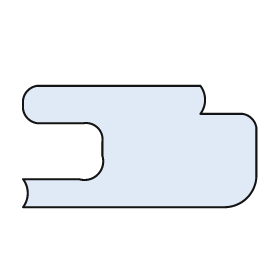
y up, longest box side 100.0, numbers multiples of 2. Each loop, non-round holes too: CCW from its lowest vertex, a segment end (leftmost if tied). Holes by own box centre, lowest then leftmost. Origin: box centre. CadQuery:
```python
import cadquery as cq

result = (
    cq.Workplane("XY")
    .moveTo(-50.0, -26.0)
    .lineTo(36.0, -26.0)
    .threePointArc((46.0, -22.0), (50.0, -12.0))
    .lineTo(50.0, 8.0)
    .threePointArc((48.0, 12.0), (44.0, 14.0))
    .lineTo(26.0, 14.0)
    .threePointArc((28.0, 20.0), (26.0, 26.0))
    .lineTo(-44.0, 26.0)
    .threePointArc((-48.0, 24.0), (-50.0, 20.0))
    .lineTo(-50.0, 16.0)
    .threePointArc((-48.0, 12.0), (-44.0, 10.0))
    .lineTo(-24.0, 10.0)
    .threePointArc((-18.0, 8.0), (-16.0, 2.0))
    .lineTo(-16.0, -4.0)
    .threePointArc((-18.0, -12.0), (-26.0, -14.0))
    .lineTo(-50.0, -14.0)
    .threePointArc((-48.0, -20.0), (-50.0, -26.0))
    .close()
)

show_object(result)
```